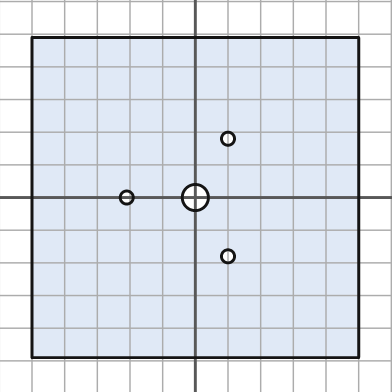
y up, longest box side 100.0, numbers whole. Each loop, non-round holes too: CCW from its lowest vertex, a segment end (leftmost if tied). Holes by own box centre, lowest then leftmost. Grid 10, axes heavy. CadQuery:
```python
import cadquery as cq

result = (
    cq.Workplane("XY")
    .moveTo(-50.0, -49.0)
    .lineTo(50.0, -49.0)
    .lineTo(50.0, 49.0)
    .lineTo(-50.0, 49.0)
    .close()
    .moveTo(10.0, -18.0)
    .circle(2.0)
    .moveTo(-21.0, 0.0)
    .circle(2.0)
    .moveTo(0.0, 0.0)
    .circle(4.0)
    .moveTo(10.0, 18.0)
    .circle(2.0)
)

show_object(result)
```